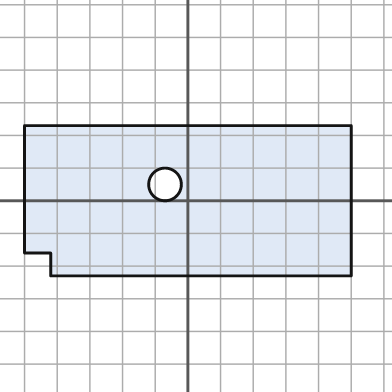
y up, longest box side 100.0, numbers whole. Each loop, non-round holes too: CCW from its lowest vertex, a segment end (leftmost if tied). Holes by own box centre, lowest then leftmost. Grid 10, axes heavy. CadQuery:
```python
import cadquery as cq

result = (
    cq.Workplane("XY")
    .moveTo(-42.0, -23.0)
    .lineTo(50.0, -23.0)
    .lineTo(50.0, 23.0)
    .lineTo(-50.0, 23.0)
    .lineTo(-50.0, -16.0)
    .lineTo(-42.0, -16.0)
    .close()
    .moveTo(-7.0, 5.0)
    .circle(5.0)
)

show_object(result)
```